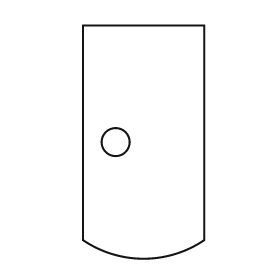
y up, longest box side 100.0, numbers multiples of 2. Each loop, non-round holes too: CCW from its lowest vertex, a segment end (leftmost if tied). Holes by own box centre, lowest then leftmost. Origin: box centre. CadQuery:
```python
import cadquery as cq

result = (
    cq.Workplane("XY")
    .moveTo(-26.0, -42.0)
    .threePointArc((0.0, -50.0), (26.0, -42.0))
    .lineTo(26.0, 50.0)
    .lineTo(-26.0, 50.0)
    .close()
    .moveTo(-12.0, 0.0)
    .circle(6.0)
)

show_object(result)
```